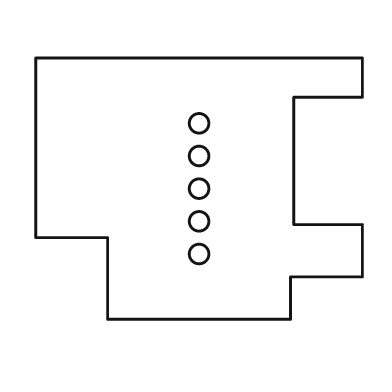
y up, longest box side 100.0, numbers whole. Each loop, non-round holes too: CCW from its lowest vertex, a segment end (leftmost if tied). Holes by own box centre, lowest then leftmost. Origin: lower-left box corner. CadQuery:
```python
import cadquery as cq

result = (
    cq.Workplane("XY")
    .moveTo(22.0, 0.0)
    .lineTo(78.0, 0.0)
    .lineTo(78.0, 13.0)
    .lineTo(100.0, 13.0)
    .lineTo(100.0, 29.0)
    .lineTo(79.0, 29.0)
    .lineTo(79.0, 68.0)
    .lineTo(100.0, 68.0)
    .lineTo(100.0, 80.0)
    .lineTo(0.0, 80.0)
    .lineTo(0.0, 25.0)
    .lineTo(22.0, 25.0)
    .close()
    .moveTo(50.0, 20.0)
    .circle(3.0)
    .moveTo(50.0, 30.0)
    .circle(3.0)
    .moveTo(50.0, 40.0)
    .circle(3.0)
    .moveTo(50.0, 50.0)
    .circle(3.0)
    .moveTo(50.0, 60.0)
    .circle(3.0)
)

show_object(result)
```